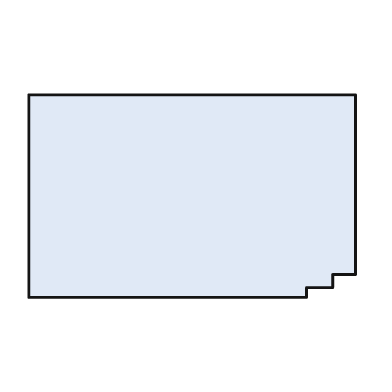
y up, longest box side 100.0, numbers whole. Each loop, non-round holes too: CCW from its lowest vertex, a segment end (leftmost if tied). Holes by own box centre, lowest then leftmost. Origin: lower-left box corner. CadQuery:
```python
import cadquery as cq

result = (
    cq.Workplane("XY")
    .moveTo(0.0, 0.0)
    .lineTo(85.0, 0.0)
    .lineTo(85.0, 3.0)
    .lineTo(93.0, 3.0)
    .lineTo(93.0, 7.0)
    .lineTo(100.0, 7.0)
    .lineTo(100.0, 62.0)
    .lineTo(0.0, 62.0)
    .close()
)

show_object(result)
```